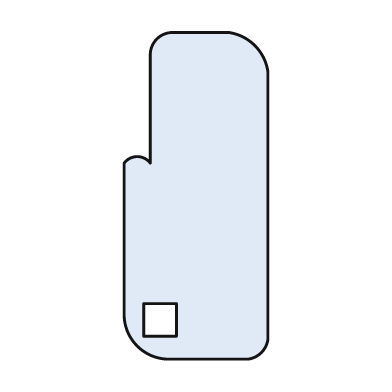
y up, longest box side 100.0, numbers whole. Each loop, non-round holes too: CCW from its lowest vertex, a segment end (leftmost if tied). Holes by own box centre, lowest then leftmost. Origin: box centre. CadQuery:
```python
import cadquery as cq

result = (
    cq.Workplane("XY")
    .moveTo(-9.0, -50.0)
    .lineTo(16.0, -50.0)
    .threePointArc((20.0, -48.0), (22.0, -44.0))
    .lineTo(22.0, 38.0)
    .threePointArc((18.0, 46.0), (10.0, 50.0))
    .lineTo(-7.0, 50.0)
    .threePointArc((-12.0, 48.0), (-14.0, 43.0))
    .lineTo(-14.0, 10.0)
    .threePointArc((-18.0, 12.0), (-22.0, 10.0))
    .lineTo(-22.0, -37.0)
    .threePointArc((-18.0, -46.0), (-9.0, -50.0))
    .close()
    .moveTo(-16.0, -43.0)
    .lineTo(-6.0, -43.0)
    .lineTo(-6.0, -33.0)
    .lineTo(-16.0, -33.0)
    .close()
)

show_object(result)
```